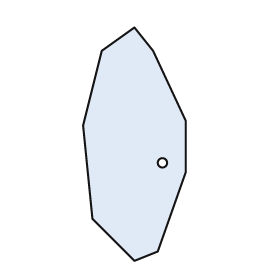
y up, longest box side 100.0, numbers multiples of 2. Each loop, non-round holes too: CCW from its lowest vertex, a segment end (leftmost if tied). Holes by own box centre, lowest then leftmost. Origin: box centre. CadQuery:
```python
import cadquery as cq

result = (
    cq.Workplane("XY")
    .moveTo(0.0, -50.0)
    .lineTo(10.0, -46.0)
    .lineTo(22.0, -12.0)
    .lineTo(22.0, 10.0)
    .lineTo(8.0, 40.0)
    .lineTo(0.0, 50.0)
    .lineTo(-14.0, 40.0)
    .lineTo(-22.0, 8.0)
    .lineTo(-18.0, -32.0)
    .close()
    .moveTo(12.0, -8.0)
    .circle(2.0)
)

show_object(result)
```